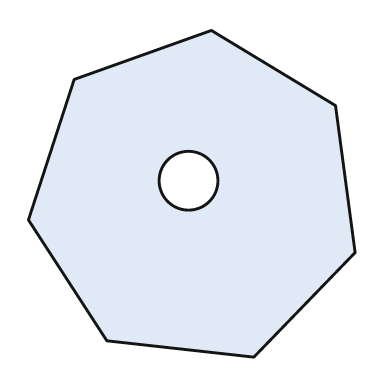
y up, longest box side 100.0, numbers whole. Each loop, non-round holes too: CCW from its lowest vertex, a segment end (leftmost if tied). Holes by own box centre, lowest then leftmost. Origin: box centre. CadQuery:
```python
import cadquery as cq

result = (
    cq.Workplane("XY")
    .moveTo(19.0, -50.0)
    .lineTo(50.0, -18.0)
    .lineTo(44.0, 27.0)
    .lineTo(6.0, 50.0)
    .lineTo(-36.0, 35.0)
    .lineTo(-50.0, -8.0)
    .lineTo(-26.0, -45.0)
    .close()
    .moveTo(-1.0, 4.0)
    .circle(9.0)
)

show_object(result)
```